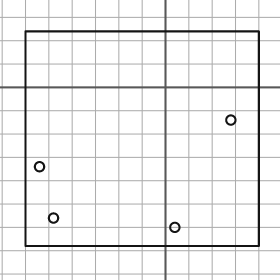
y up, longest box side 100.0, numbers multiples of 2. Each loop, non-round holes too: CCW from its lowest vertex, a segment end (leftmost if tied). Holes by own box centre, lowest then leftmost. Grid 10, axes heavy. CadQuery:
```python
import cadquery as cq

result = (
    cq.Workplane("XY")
    .moveTo(-60.0, -68.0)
    .lineTo(40.0, -68.0)
    .lineTo(40.0, 24.0)
    .lineTo(-60.0, 24.0)
    .close()
    .moveTo(4.0, -60.0)
    .circle(2.0)
    .moveTo(-48.0, -56.0)
    .circle(2.0)
    .moveTo(-54.0, -34.0)
    .circle(2.0)
    .moveTo(28.0, -14.0)
    .circle(2.0)
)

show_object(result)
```